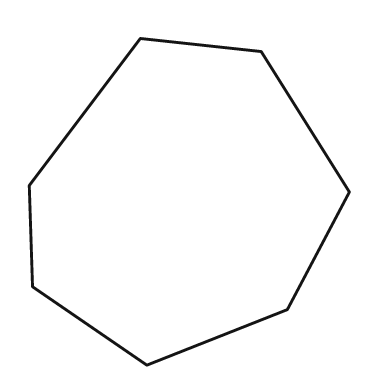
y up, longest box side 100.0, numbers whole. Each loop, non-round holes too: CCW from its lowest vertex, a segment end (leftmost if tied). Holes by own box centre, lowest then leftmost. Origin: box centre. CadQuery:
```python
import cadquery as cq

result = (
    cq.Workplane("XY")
    .moveTo(-13.0, -50.0)
    .lineTo(30.0, -33.0)
    .lineTo(49.0, 3.0)
    .lineTo(22.0, 46.0)
    .lineTo(-15.0, 50.0)
    .lineTo(-49.0, 5.0)
    .lineTo(-48.0, -26.0)
    .close()
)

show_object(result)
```